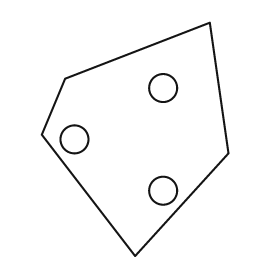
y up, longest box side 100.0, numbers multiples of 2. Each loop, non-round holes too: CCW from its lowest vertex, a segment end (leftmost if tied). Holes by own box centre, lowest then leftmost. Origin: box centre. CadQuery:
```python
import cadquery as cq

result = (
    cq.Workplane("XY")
    .moveTo(0.0, -50.0)
    .lineTo(40.0, -6.0)
    .lineTo(32.0, 50.0)
    .lineTo(-30.0, 26.0)
    .lineTo(-40.0, 2.0)
    .close()
    .moveTo(12.0, -22.0)
    .circle(6.0)
    .moveTo(-26.0, 0.0)
    .circle(6.0)
    .moveTo(12.0, 22.0)
    .circle(6.0)
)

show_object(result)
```